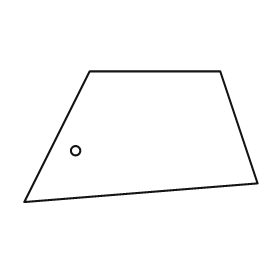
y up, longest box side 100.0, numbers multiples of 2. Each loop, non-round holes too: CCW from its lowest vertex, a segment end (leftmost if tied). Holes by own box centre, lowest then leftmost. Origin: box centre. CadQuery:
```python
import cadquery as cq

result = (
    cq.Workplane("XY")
    .moveTo(-50.0, -28.0)
    .lineTo(50.0, -20.0)
    .lineTo(34.0, 28.0)
    .lineTo(-22.0, 28.0)
    .close()
    .moveTo(-28.0, -6.0)
    .circle(2.0)
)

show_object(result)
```